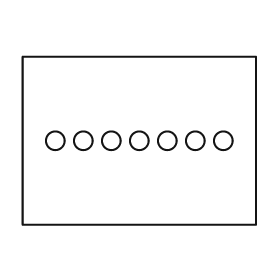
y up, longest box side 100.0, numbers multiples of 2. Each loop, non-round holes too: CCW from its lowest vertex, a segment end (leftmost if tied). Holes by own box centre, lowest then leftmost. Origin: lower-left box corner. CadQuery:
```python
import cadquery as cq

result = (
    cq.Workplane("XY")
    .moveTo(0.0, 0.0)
    .lineTo(100.0, 0.0)
    .lineTo(100.0, 72.0)
    .lineTo(0.0, 72.0)
    .close()
    .moveTo(14.0, 36.0)
    .circle(4.0)
    .moveTo(26.0, 36.0)
    .circle(4.0)
    .moveTo(38.0, 36.0)
    .circle(4.0)
    .moveTo(50.0, 36.0)
    .circle(4.0)
    .moveTo(62.0, 36.0)
    .circle(4.0)
    .moveTo(74.0, 36.0)
    .circle(4.0)
    .moveTo(86.0, 36.0)
    .circle(4.0)
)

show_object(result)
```